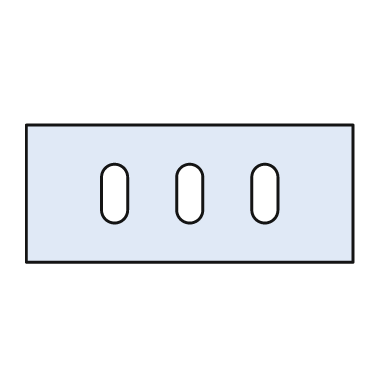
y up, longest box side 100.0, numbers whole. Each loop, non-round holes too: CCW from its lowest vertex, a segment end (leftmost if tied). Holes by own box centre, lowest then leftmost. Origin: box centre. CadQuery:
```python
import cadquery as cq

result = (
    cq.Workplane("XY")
    .moveTo(-50.0, -21.0)
    .lineTo(50.0, -21.0)
    .lineTo(50.0, 21.0)
    .lineTo(-50.0, 21.0)
    .close()
    .moveTo(-27.0, -5.0)
    .threePointArc((-23.0, -9.0), (-19.0, -5.0))
    .lineTo(-19.0, 5.0)
    .threePointArc((-23.0, 9.0), (-27.0, 5.0))
    .close()
    .moveTo(-4.0, -5.0)
    .threePointArc((0.0, -9.0), (4.0, -5.0))
    .lineTo(4.0, 5.0)
    .threePointArc((0.0, 9.0), (-4.0, 5.0))
    .close()
    .moveTo(19.0, -5.0)
    .threePointArc((23.0, -9.0), (27.0, -5.0))
    .lineTo(27.0, 5.0)
    .threePointArc((23.0, 9.0), (19.0, 5.0))
    .close()
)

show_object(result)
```